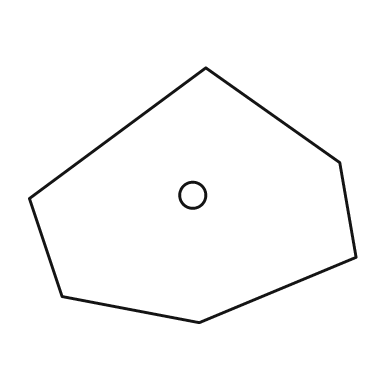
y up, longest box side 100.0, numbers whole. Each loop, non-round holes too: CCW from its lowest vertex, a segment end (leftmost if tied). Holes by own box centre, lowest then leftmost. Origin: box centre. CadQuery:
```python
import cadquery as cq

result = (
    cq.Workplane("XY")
    .moveTo(2.0, -39.0)
    .lineTo(50.0, -19.0)
    .lineTo(45.0, 10.0)
    .lineTo(4.0, 39.0)
    .lineTo(-50.0, -1.0)
    .lineTo(-40.0, -31.0)
    .close()
    .moveTo(0.0, 0.0)
    .circle(4.0)
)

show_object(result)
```